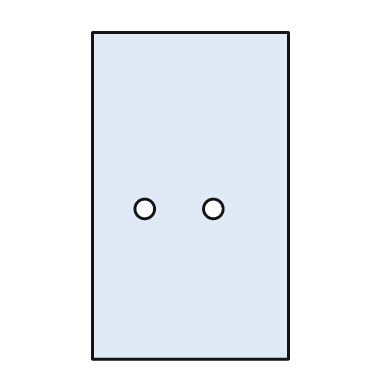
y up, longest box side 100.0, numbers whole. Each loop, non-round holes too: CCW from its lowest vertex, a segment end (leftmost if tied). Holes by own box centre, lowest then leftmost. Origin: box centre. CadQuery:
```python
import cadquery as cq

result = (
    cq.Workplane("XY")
    .moveTo(-30.0, -50.0)
    .lineTo(30.0, -50.0)
    .lineTo(30.0, 50.0)
    .lineTo(-30.0, 50.0)
    .close()
    .moveTo(-14.0, -4.0)
    .circle(3.0)
    .moveTo(7.0, -4.0)
    .circle(3.0)
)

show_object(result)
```